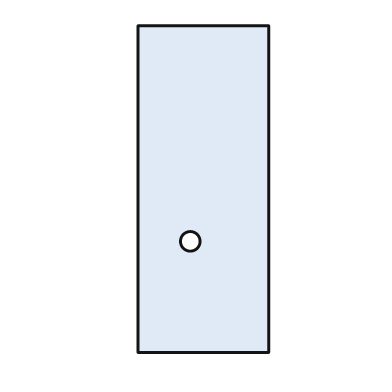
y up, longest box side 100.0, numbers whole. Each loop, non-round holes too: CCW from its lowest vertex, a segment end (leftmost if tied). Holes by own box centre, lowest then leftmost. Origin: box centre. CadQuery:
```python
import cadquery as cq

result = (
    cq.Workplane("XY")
    .moveTo(-20.0, -50.0)
    .lineTo(20.0, -50.0)
    .lineTo(20.0, 50.0)
    .lineTo(-20.0, 50.0)
    .close()
    .moveTo(-4.0, -16.0)
    .circle(3.0)
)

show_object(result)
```